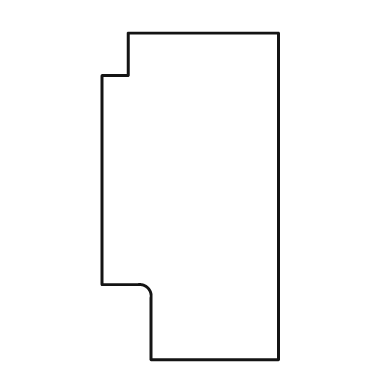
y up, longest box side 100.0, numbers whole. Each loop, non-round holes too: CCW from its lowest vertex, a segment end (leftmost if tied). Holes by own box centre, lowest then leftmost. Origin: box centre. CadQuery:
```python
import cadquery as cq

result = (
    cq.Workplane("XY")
    .moveTo(-12.0, -50.0)
    .lineTo(27.0, -50.0)
    .lineTo(27.0, 50.0)
    .lineTo(-19.0, 50.0)
    .lineTo(-19.0, 37.0)
    .lineTo(-27.0, 37.0)
    .lineTo(-27.0, -27.0)
    .lineTo(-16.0, -27.0)
    .threePointArc((-13.0, -28.0), (-12.0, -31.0))
    .close()
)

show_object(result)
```